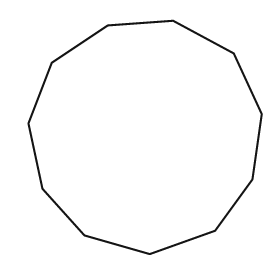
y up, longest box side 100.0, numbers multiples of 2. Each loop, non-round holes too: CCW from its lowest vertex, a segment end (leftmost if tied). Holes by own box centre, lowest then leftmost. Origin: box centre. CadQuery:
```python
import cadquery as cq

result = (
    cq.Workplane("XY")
    .moveTo(2.0, -50.0)
    .lineTo(30.0, -40.0)
    .lineTo(46.0, -18.0)
    .lineTo(50.0, 10.0)
    .lineTo(38.0, 36.0)
    .lineTo(12.0, 50.0)
    .lineTo(-16.0, 48.0)
    .lineTo(-40.0, 32.0)
    .lineTo(-50.0, 6.0)
    .lineTo(-44.0, -22.0)
    .lineTo(-26.0, -42.0)
    .close()
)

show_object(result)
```